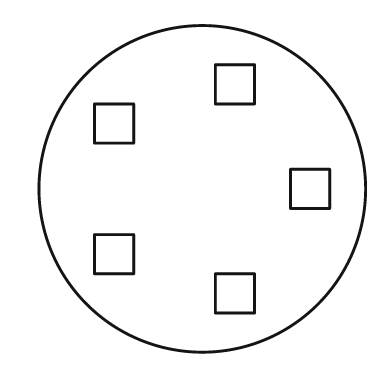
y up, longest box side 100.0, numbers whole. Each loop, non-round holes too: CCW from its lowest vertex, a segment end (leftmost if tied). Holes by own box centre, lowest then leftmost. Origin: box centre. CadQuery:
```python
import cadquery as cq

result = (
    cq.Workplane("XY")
    .moveTo(0.0, 0.0)
    .circle(50.0)
    .moveTo(4.0, -38.0)
    .lineTo(16.0, -38.0)
    .lineTo(16.0, -26.0)
    .lineTo(4.0, -26.0)
    .close()
    .moveTo(-33.0, -26.0)
    .lineTo(-21.0, -26.0)
    .lineTo(-21.0, -14.0)
    .lineTo(-33.0, -14.0)
    .close()
    .moveTo(27.0, -6.0)
    .lineTo(39.0, -6.0)
    .lineTo(39.0, 6.0)
    .lineTo(27.0, 6.0)
    .close()
    .moveTo(-33.0, 14.0)
    .lineTo(-21.0, 14.0)
    .lineTo(-21.0, 26.0)
    .lineTo(-33.0, 26.0)
    .close()
    .moveTo(4.0, 26.0)
    .lineTo(16.0, 26.0)
    .lineTo(16.0, 38.0)
    .lineTo(4.0, 38.0)
    .close()
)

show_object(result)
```